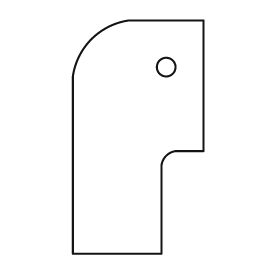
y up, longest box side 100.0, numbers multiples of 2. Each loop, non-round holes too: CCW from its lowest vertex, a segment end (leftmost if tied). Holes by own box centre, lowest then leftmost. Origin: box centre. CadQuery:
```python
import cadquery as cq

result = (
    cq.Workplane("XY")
    .moveTo(-28.0, -50.0)
    .lineTo(10.0, -50.0)
    .lineTo(10.0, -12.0)
    .threePointArc((12.0, -8.0), (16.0, -6.0))
    .lineTo(28.0, -6.0)
    .lineTo(28.0, 50.0)
    .lineTo(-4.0, 50.0)
    .threePointArc((-20.0, 42.0), (-28.0, 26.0))
    .close()
    .moveTo(12.0, 30.0)
    .circle(4.0)
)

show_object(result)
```